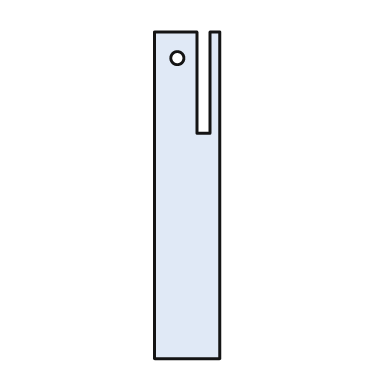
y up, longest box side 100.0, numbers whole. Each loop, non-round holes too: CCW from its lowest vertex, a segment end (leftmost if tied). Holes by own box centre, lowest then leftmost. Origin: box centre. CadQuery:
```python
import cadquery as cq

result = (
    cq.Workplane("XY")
    .moveTo(-10.0, -50.0)
    .lineTo(10.0, -50.0)
    .lineTo(10.0, 50.0)
    .lineTo(7.0, 50.0)
    .lineTo(7.0, 19.0)
    .lineTo(3.0, 19.0)
    .lineTo(3.0, 50.0)
    .lineTo(-10.0, 50.0)
    .close()
    .moveTo(-3.0, 42.0)
    .circle(2.0)
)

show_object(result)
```